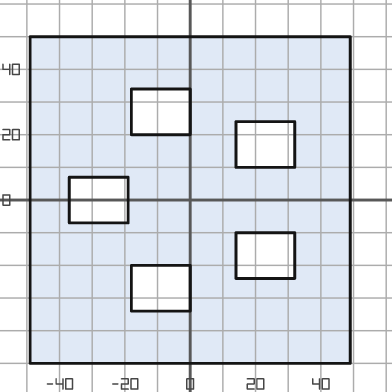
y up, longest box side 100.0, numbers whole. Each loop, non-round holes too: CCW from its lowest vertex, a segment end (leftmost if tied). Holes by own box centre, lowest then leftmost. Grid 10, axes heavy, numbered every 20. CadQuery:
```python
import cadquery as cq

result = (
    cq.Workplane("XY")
    .moveTo(-49.0, -50.0)
    .lineTo(49.0, -50.0)
    .lineTo(49.0, 50.0)
    .lineTo(-49.0, 50.0)
    .close()
    .moveTo(-18.0, -34.0)
    .lineTo(0.0, -34.0)
    .lineTo(0.0, -20.0)
    .lineTo(-18.0, -20.0)
    .close()
    .moveTo(14.0, -24.0)
    .lineTo(32.0, -24.0)
    .lineTo(32.0, -10.0)
    .lineTo(14.0, -10.0)
    .close()
    .moveTo(-37.0, -7.0)
    .lineTo(-19.0, -7.0)
    .lineTo(-19.0, 7.0)
    .lineTo(-37.0, 7.0)
    .close()
    .moveTo(14.0, 10.0)
    .lineTo(32.0, 10.0)
    .lineTo(32.0, 24.0)
    .lineTo(14.0, 24.0)
    .close()
    .moveTo(-18.0, 20.0)
    .lineTo(0.0, 20.0)
    .lineTo(0.0, 34.0)
    .lineTo(-18.0, 34.0)
    .close()
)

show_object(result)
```